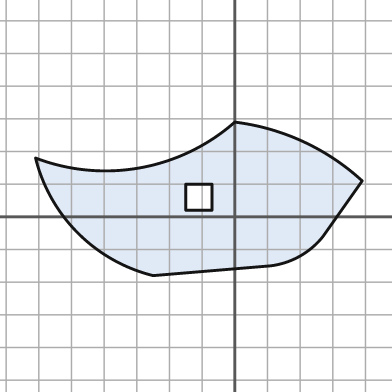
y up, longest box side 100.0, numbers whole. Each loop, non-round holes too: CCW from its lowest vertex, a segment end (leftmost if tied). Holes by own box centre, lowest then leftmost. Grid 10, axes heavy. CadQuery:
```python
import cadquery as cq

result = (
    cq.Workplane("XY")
    .moveTo(-25.0, -18.0)
    .lineTo(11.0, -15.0)
    .threePointArc((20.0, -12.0), (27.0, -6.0))
    .lineTo(39.0, 11.0)
    .threePointArc((21.0, 23.0), (0.0, 29.0))
    .threePointArc((-29.0, 15.0), (-61.0, 18.0))
    .threePointArc((-48.0, -5.0), (-25.0, -18.0))
    .close()
    .moveTo(-15.0, 2.0)
    .lineTo(-7.0, 2.0)
    .lineTo(-7.0, 10.0)
    .lineTo(-15.0, 10.0)
    .close()
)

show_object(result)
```